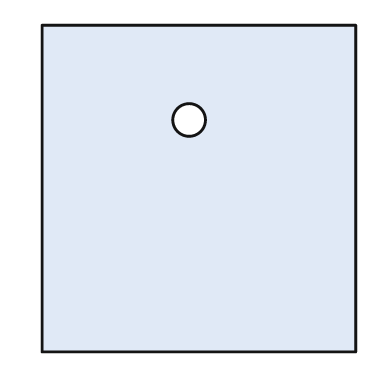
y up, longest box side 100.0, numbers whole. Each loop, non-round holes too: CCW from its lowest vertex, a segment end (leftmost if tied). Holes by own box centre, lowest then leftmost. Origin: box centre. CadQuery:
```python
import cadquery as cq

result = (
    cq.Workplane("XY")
    .moveTo(-48.0, -50.0)
    .lineTo(48.0, -50.0)
    .lineTo(48.0, 50.0)
    .lineTo(-48.0, 50.0)
    .close()
    .moveTo(-3.0, 21.0)
    .circle(5.0)
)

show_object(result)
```